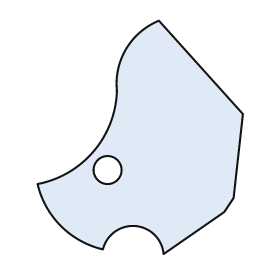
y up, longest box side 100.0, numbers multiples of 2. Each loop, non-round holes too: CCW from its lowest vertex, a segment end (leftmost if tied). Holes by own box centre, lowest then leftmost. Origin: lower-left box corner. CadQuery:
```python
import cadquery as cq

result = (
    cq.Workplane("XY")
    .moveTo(54.0, 0.0)
    .lineTo(80.0, 18.0)
    .lineTo(84.0, 24.0)
    .lineTo(88.0, 60.0)
    .lineTo(52.0, 100.0)
    .threePointArc((38.0, 88.0), (34.0, 70.0))
    .threePointArc((24.0, 44.0), (0.0, 30.0))
    .threePointArc((10.0, 12.0), (28.0, 2.0))
    .threePointArc((42.0, 12.0), (54.0, 0.0))
    .close()
    .moveTo(30.0, 36.0)
    .circle(6.0)
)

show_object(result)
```